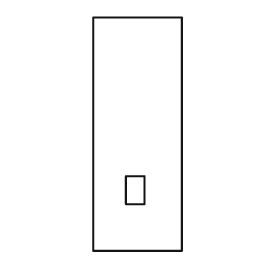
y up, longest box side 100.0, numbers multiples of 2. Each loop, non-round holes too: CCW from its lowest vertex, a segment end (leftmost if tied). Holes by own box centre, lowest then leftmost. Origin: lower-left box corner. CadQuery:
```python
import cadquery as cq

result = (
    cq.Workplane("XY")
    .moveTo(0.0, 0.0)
    .lineTo(38.0, 0.0)
    .lineTo(38.0, 100.0)
    .lineTo(0.0, 100.0)
    .close()
    .moveTo(14.0, 20.0)
    .lineTo(22.0, 20.0)
    .lineTo(22.0, 32.0)
    .lineTo(14.0, 32.0)
    .close()
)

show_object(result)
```